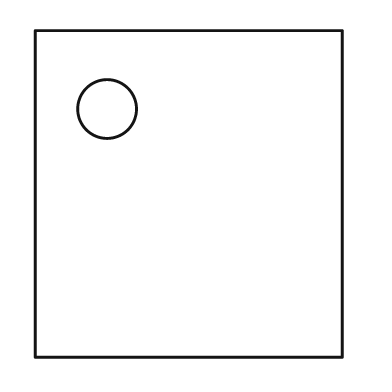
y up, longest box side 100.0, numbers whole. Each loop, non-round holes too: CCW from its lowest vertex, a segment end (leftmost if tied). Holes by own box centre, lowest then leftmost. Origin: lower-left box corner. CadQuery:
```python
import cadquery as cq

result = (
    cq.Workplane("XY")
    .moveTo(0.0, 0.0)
    .lineTo(94.0, 0.0)
    .lineTo(94.0, 100.0)
    .lineTo(0.0, 100.0)
    .close()
    .moveTo(22.0, 76.0)
    .circle(9.0)
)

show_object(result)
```